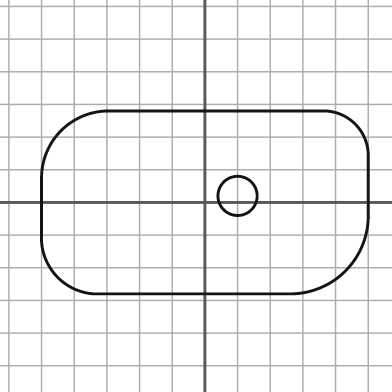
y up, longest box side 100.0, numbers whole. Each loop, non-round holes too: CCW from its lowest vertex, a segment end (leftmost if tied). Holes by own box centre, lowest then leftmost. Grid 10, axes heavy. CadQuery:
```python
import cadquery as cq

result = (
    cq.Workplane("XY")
    .moveTo(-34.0, -28.0)
    .lineTo(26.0, -28.0)
    .threePointArc((43.0, -21.0), (50.0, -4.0))
    .lineTo(50.0, 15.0)
    .threePointArc((46.0, 24.0), (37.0, 28.0))
    .lineTo(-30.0, 28.0)
    .threePointArc((-44.0, 22.0), (-50.0, 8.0))
    .lineTo(-50.0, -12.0)
    .threePointArc((-45.0, -23.0), (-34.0, -28.0))
    .close()
    .moveTo(10.0, 2.0)
    .circle(6.0)
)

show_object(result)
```